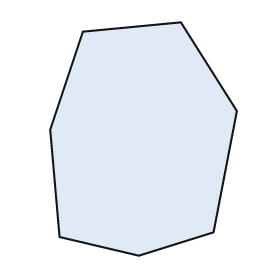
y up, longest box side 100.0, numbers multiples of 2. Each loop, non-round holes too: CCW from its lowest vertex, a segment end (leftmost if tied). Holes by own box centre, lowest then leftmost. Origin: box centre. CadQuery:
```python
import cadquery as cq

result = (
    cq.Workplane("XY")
    .moveTo(-2.0, -50.0)
    .lineTo(30.0, -40.0)
    .lineTo(40.0, 12.0)
    .lineTo(16.0, 50.0)
    .lineTo(-26.0, 46.0)
    .lineTo(-40.0, 4.0)
    .lineTo(-36.0, -42.0)
    .close()
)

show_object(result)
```